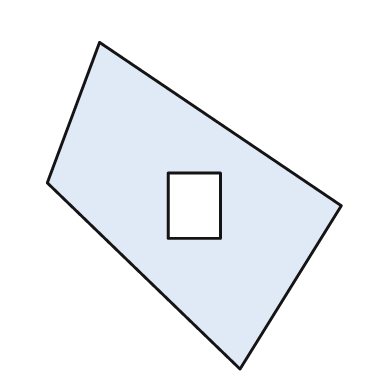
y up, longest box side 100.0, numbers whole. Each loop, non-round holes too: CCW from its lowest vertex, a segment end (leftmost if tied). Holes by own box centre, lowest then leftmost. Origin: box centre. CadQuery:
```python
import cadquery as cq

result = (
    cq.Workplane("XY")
    .moveTo(14.0, -50.0)
    .lineTo(45.0, 0.0)
    .lineTo(-29.0, 50.0)
    .lineTo(-45.0, 7.0)
    .close()
    .moveTo(-8.0, -10.0)
    .lineTo(8.0, -10.0)
    .lineTo(8.0, 10.0)
    .lineTo(-8.0, 10.0)
    .close()
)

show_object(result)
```